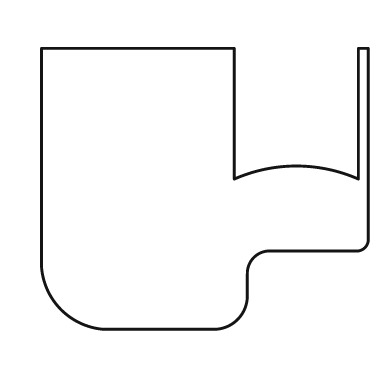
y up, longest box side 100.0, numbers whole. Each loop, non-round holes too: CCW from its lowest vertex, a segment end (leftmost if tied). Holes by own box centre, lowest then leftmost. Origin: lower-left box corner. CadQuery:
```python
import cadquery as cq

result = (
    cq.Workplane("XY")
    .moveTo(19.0, 0.0)
    .lineTo(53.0, 0.0)
    .threePointArc((60.0, 3.0), (63.0, 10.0))
    .lineTo(63.0, 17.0)
    .threePointArc((65.0, 22.0), (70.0, 24.0))
    .lineTo(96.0, 24.0)
    .threePointArc((99.0, 25.0), (100.0, 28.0))
    .lineTo(100.0, 86.0)
    .lineTo(97.0, 86.0)
    .lineTo(97.0, 46.0)
    .threePointArc((78.0, 50.0), (59.0, 46.0))
    .lineTo(59.0, 86.0)
    .lineTo(0.0, 86.0)
    .lineTo(0.0, 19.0)
    .threePointArc((6.0, 6.0), (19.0, 0.0))
    .close()
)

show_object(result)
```